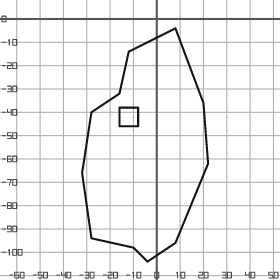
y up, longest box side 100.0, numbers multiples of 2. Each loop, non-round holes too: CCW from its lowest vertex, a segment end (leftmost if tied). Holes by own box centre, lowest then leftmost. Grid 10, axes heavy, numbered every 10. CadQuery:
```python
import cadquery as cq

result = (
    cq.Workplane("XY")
    .moveTo(-4.0, -104.0)
    .lineTo(8.0, -96.0)
    .lineTo(22.0, -62.0)
    .lineTo(20.0, -36.0)
    .lineTo(8.0, -4.0)
    .lineTo(-12.0, -14.0)
    .lineTo(-16.0, -32.0)
    .lineTo(-28.0, -40.0)
    .lineTo(-32.0, -66.0)
    .lineTo(-28.0, -94.0)
    .lineTo(-10.0, -98.0)
    .close()
    .moveTo(-16.0, -46.0)
    .lineTo(-8.0, -46.0)
    .lineTo(-8.0, -38.0)
    .lineTo(-16.0, -38.0)
    .close()
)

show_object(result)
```